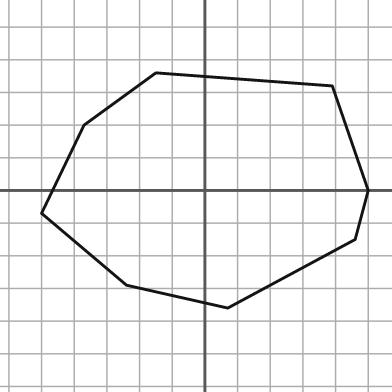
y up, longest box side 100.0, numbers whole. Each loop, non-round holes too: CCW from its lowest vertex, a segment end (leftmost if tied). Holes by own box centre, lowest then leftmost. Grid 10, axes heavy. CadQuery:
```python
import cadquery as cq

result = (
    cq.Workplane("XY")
    .moveTo(7.0, -36.0)
    .lineTo(46.0, -15.0)
    .lineTo(50.0, 0.0)
    .lineTo(39.0, 32.0)
    .lineTo(-15.0, 36.0)
    .lineTo(-37.0, 20.0)
    .lineTo(-50.0, -7.0)
    .lineTo(-24.0, -29.0)
    .close()
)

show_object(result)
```